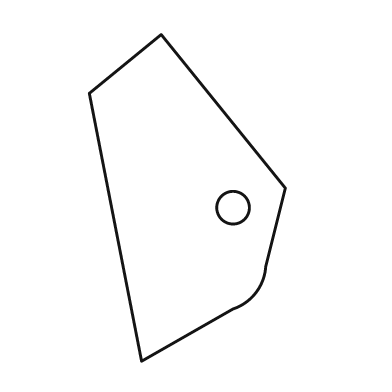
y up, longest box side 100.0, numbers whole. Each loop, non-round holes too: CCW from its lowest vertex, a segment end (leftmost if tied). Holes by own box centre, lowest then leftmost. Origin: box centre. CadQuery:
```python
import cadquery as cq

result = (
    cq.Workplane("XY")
    .moveTo(-14.0, -50.0)
    .lineTo(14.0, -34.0)
    .threePointArc((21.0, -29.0), (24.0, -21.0))
    .lineTo(30.0, 3.0)
    .lineTo(-8.0, 50.0)
    .lineTo(-30.0, 32.0)
    .close()
    .moveTo(14.0, -3.0)
    .circle(5.0)
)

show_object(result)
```